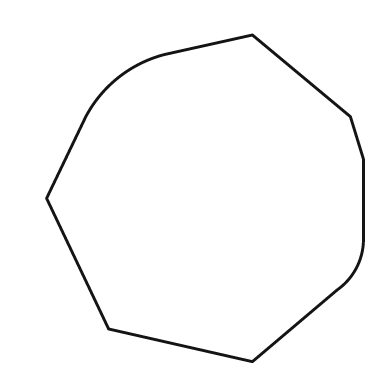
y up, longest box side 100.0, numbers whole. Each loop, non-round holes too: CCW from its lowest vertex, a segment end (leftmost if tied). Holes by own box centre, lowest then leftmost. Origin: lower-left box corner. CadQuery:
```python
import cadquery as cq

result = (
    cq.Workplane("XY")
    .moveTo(63.0, 0.0)
    .lineTo(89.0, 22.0)
    .threePointArc((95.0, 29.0), (97.0, 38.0))
    .lineTo(97.0, 62.0)
    .lineTo(93.0, 75.0)
    .lineTo(63.0, 100.0)
    .lineTo(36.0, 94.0)
    .threePointArc((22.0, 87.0), (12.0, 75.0))
    .lineTo(0.0, 50.0)
    .lineTo(19.0, 10.0)
    .close()
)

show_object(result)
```